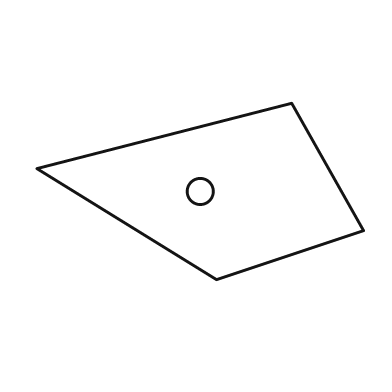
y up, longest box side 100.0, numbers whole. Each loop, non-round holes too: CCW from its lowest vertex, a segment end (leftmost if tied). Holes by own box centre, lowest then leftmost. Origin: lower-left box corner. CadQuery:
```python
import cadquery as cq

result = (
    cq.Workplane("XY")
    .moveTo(55.0, 0.0)
    .lineTo(100.0, 15.0)
    .lineTo(78.0, 54.0)
    .lineTo(0.0, 34.0)
    .close()
    .moveTo(50.0, 27.0)
    .circle(4.0)
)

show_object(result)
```